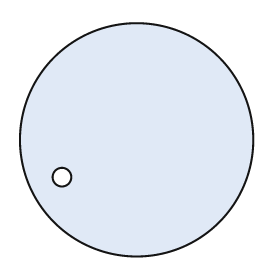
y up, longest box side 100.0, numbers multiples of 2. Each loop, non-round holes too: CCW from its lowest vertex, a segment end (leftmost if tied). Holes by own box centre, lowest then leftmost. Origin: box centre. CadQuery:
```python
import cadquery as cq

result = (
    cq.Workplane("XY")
    .moveTo(0.0, 0.0)
    .circle(50.0)
    .moveTo(-32.0, -16.0)
    .circle(4.0)
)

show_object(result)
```